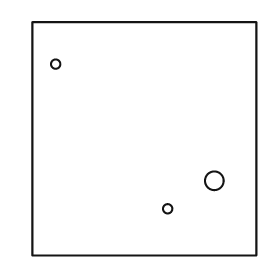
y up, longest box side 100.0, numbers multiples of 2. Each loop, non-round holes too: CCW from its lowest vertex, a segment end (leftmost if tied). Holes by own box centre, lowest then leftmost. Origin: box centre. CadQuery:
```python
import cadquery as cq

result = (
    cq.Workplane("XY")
    .moveTo(-48.0, -50.0)
    .lineTo(48.0, -50.0)
    .lineTo(48.0, 50.0)
    .lineTo(-48.0, 50.0)
    .close()
    .moveTo(10.0, -30.0)
    .circle(2.0)
    .moveTo(30.0, -18.0)
    .circle(4.0)
    .moveTo(-38.0, 32.0)
    .circle(2.0)
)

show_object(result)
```